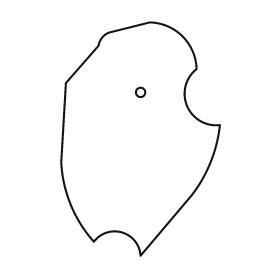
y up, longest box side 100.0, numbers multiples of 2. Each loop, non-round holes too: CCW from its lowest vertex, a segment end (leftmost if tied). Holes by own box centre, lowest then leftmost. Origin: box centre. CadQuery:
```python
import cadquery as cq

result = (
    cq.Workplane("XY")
    .moveTo(0.0, -50.0)
    .lineTo(22.0, -24.0)
    .threePointArc((30.0, -10.0), (34.0, 6.0))
    .threePointArc((20.0, 14.0), (24.0, 30.0))
    .threePointArc((18.0, 44.0), (4.0, 50.0))
    .lineTo(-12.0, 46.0)
    .threePointArc((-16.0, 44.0), (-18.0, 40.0))
    .lineTo(-32.0, 24.0)
    .lineTo(-34.0, -10.0)
    .threePointArc((-30.0, -28.0), (-20.0, -44.0))
    .threePointArc((-8.0, -40.0), (0.0, -50.0))
    .close()
    .moveTo(0.0, 20.0)
    .circle(2.0)
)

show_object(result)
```